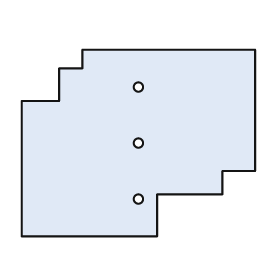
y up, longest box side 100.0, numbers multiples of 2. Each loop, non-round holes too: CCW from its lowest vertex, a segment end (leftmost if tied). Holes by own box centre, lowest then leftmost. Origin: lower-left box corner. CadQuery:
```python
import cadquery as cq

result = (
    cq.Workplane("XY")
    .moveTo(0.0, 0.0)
    .lineTo(58.0, 0.0)
    .lineTo(58.0, 18.0)
    .lineTo(86.0, 18.0)
    .lineTo(86.0, 28.0)
    .lineTo(100.0, 28.0)
    .lineTo(100.0, 80.0)
    .lineTo(26.0, 80.0)
    .lineTo(26.0, 72.0)
    .lineTo(16.0, 72.0)
    .lineTo(16.0, 58.0)
    .lineTo(0.0, 58.0)
    .close()
    .moveTo(50.0, 16.0)
    .circle(2.0)
    .moveTo(50.0, 40.0)
    .circle(2.0)
    .moveTo(50.0, 64.0)
    .circle(2.0)
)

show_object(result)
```